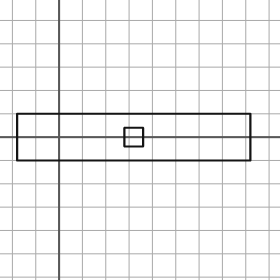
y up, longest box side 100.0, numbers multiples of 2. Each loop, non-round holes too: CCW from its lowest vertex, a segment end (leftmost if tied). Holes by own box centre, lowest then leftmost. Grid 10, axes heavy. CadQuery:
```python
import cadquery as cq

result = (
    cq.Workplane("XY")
    .moveTo(-18.0, -10.0)
    .lineTo(82.0, -10.0)
    .lineTo(82.0, 10.0)
    .lineTo(-18.0, 10.0)
    .close()
    .moveTo(28.0, -4.0)
    .lineTo(36.0, -4.0)
    .lineTo(36.0, 4.0)
    .lineTo(28.0, 4.0)
    .close()
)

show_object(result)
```